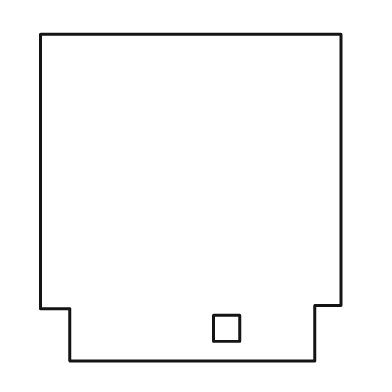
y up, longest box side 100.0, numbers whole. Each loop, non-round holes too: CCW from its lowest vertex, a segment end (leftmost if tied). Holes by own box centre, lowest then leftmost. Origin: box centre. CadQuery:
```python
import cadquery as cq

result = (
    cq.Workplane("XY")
    .moveTo(-37.0, -50.0)
    .lineTo(38.0, -50.0)
    .lineTo(38.0, -33.0)
    .lineTo(46.0, -33.0)
    .lineTo(46.0, 50.0)
    .lineTo(-46.0, 50.0)
    .lineTo(-46.0, -34.0)
    .lineTo(-37.0, -34.0)
    .close()
    .moveTo(7.0, -44.0)
    .lineTo(15.0, -44.0)
    .lineTo(15.0, -36.0)
    .lineTo(7.0, -36.0)
    .close()
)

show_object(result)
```